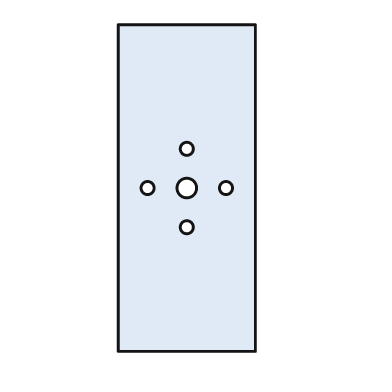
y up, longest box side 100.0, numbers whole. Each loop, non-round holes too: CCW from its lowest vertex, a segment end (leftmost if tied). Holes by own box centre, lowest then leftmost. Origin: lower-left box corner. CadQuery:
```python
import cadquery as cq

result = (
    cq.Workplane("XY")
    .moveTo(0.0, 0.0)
    .lineTo(42.0, 0.0)
    .lineTo(42.0, 100.0)
    .lineTo(0.0, 100.0)
    .close()
    .moveTo(21.0, 38.0)
    .circle(2.0)
    .moveTo(9.0, 50.0)
    .circle(2.0)
    .moveTo(21.0, 50.0)
    .circle(3.0)
    .moveTo(33.0, 50.0)
    .circle(2.0)
    .moveTo(21.0, 62.0)
    .circle(2.0)
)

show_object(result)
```